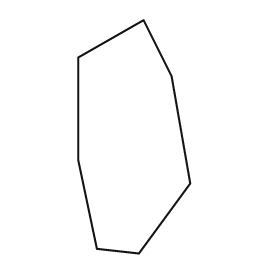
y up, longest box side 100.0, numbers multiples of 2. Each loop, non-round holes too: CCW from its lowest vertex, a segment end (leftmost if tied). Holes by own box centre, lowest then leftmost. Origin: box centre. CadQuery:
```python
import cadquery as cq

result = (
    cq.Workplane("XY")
    .moveTo(2.0, -50.0)
    .lineTo(24.0, -20.0)
    .lineTo(16.0, 26.0)
    .lineTo(4.0, 50.0)
    .lineTo(-24.0, 34.0)
    .lineTo(-24.0, -10.0)
    .lineTo(-16.0, -48.0)
    .close()
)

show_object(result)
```